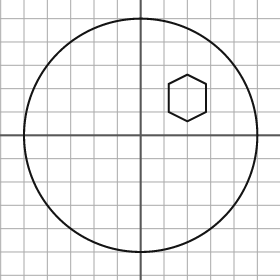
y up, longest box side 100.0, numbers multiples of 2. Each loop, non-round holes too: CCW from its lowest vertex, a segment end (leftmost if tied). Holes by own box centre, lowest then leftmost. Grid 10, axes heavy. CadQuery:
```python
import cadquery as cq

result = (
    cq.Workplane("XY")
    .moveTo(0.0, 0.0)
    .circle(50.0)
    .moveTo(20.0, 6.0)
    .lineTo(28.0, 10.0)
    .lineTo(28.0, 22.0)
    .lineTo(20.0, 26.0)
    .lineTo(12.0, 22.0)
    .lineTo(12.0, 10.0)
    .close()
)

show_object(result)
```